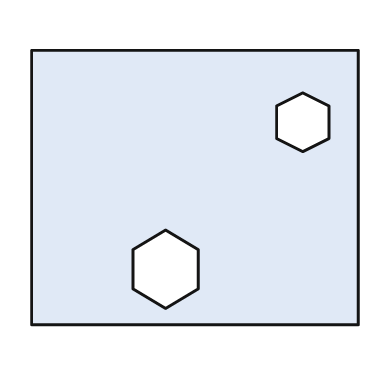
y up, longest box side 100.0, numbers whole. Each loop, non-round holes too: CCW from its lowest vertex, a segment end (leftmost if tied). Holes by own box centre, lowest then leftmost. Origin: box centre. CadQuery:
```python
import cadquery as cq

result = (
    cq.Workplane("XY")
    .moveTo(-50.0, -42.0)
    .lineTo(50.0, -42.0)
    .lineTo(50.0, 42.0)
    .lineTo(-50.0, 42.0)
    .close()
    .moveTo(-9.0, -37.0)
    .lineTo(1.0, -31.0)
    .lineTo(1.0, -19.0)
    .lineTo(-9.0, -13.0)
    .lineTo(-19.0, -19.0)
    .lineTo(-19.0, -31.0)
    .close()
    .moveTo(33.0, 11.0)
    .lineTo(41.0, 15.0)
    .lineTo(41.0, 25.0)
    .lineTo(33.0, 29.0)
    .lineTo(25.0, 25.0)
    .lineTo(25.0, 15.0)
    .close()
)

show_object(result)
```